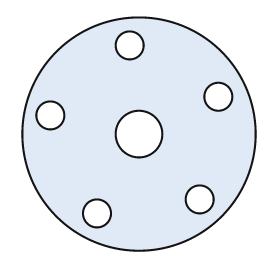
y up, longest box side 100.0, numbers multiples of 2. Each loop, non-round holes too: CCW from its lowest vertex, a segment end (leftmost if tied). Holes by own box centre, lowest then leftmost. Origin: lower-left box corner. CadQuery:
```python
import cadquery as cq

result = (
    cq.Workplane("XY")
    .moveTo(50.0, 50.0)
    .circle(50.0)
    .moveTo(32.0, 16.0)
    .circle(6.0)
    .moveTo(76.0, 22.0)
    .circle(6.0)
    .moveTo(50.0, 50.0)
    .circle(10.0)
    .moveTo(12.0, 58.0)
    .circle(6.0)
    .moveTo(84.0, 66.0)
    .circle(6.0)
    .moveTo(46.0, 88.0)
    .circle(6.0)
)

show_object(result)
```